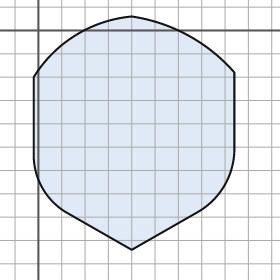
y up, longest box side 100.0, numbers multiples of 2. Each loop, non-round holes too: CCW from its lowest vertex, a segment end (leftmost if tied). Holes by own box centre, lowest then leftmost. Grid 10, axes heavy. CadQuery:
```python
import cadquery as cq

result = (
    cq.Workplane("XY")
    .moveTo(40.0, -94.0)
    .lineTo(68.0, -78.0)
    .threePointArc((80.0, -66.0), (84.0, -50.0))
    .lineTo(84.0, -18.0)
    .threePointArc((64.0, -2.0), (40.0, 6.0))
    .threePointArc((16.0, -2.0), (-2.0, -20.0))
    .lineTo(-2.0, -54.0)
    .threePointArc((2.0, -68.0), (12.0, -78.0))
    .close()
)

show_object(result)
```